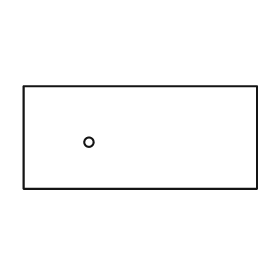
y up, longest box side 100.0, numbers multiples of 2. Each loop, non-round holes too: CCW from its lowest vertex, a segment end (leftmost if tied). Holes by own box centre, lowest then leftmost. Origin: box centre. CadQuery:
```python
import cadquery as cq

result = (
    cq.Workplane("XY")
    .moveTo(-50.0, -22.0)
    .lineTo(50.0, -22.0)
    .lineTo(50.0, 22.0)
    .lineTo(-50.0, 22.0)
    .close()
    .moveTo(-22.0, -2.0)
    .circle(2.0)
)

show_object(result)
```